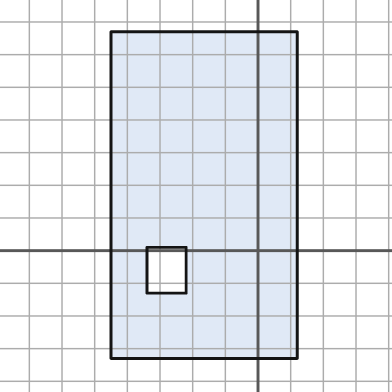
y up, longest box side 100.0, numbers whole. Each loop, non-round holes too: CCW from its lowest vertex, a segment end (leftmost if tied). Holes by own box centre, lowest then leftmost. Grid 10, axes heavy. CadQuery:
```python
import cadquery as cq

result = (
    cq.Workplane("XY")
    .moveTo(-45.0, -33.0)
    .lineTo(12.0, -33.0)
    .lineTo(12.0, 67.0)
    .lineTo(-45.0, 67.0)
    .close()
    .moveTo(-34.0, -13.0)
    .lineTo(-22.0, -13.0)
    .lineTo(-22.0, 1.0)
    .lineTo(-34.0, 1.0)
    .close()
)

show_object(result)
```